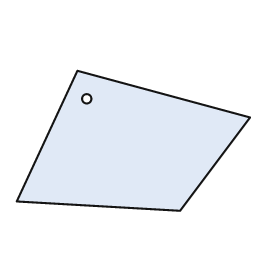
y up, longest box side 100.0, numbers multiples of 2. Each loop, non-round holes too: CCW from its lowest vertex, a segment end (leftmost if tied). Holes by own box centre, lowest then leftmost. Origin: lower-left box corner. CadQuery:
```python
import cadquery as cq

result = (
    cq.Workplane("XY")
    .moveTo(70.0, 0.0)
    .lineTo(100.0, 40.0)
    .lineTo(26.0, 60.0)
    .lineTo(0.0, 4.0)
    .close()
    .moveTo(30.0, 48.0)
    .circle(2.0)
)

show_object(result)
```